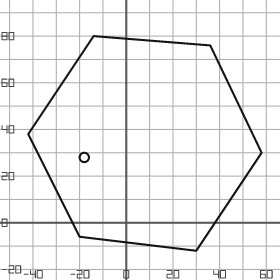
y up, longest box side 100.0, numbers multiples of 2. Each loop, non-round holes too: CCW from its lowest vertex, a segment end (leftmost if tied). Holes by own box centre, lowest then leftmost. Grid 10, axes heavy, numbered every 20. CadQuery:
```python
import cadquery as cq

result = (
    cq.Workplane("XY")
    .moveTo(30.0, -12.0)
    .lineTo(58.0, 30.0)
    .lineTo(36.0, 76.0)
    .lineTo(-14.0, 80.0)
    .lineTo(-42.0, 38.0)
    .lineTo(-20.0, -6.0)
    .close()
    .moveTo(-18.0, 28.0)
    .circle(2.0)
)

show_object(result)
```